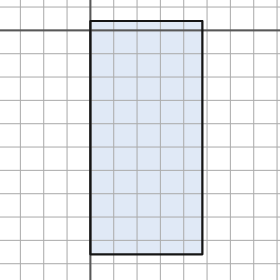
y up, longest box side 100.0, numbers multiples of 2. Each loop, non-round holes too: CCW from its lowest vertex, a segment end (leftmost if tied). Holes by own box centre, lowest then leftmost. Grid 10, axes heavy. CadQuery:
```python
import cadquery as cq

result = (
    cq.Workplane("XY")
    .moveTo(0.0, -96.0)
    .lineTo(48.0, -96.0)
    .lineTo(48.0, 4.0)
    .lineTo(0.0, 4.0)
    .close()
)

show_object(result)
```